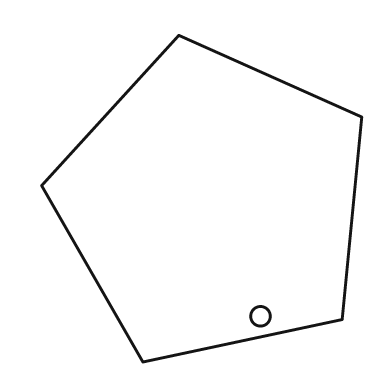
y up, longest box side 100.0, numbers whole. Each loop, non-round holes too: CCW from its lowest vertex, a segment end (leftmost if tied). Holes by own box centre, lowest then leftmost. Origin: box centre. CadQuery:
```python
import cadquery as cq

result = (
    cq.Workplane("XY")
    .moveTo(-18.0, -50.0)
    .lineTo(43.0, -37.0)
    .lineTo(49.0, 25.0)
    .lineTo(-7.0, 50.0)
    .lineTo(-49.0, 4.0)
    .close()
    .moveTo(18.0, -36.0)
    .circle(3.0)
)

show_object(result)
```